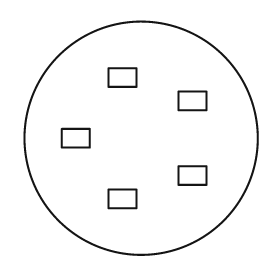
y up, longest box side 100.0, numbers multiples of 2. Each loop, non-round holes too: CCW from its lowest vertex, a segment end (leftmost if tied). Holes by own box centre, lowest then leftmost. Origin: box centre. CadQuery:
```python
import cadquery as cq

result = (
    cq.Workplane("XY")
    .moveTo(0.0, 0.0)
    .circle(50.0)
    .moveTo(-14.0, -30.0)
    .lineTo(-2.0, -30.0)
    .lineTo(-2.0, -22.0)
    .lineTo(-14.0, -22.0)
    .close()
    .moveTo(16.0, -20.0)
    .lineTo(28.0, -20.0)
    .lineTo(28.0, -12.0)
    .lineTo(16.0, -12.0)
    .close()
    .moveTo(-34.0, -4.0)
    .lineTo(-22.0, -4.0)
    .lineTo(-22.0, 4.0)
    .lineTo(-34.0, 4.0)
    .close()
    .moveTo(16.0, 12.0)
    .lineTo(28.0, 12.0)
    .lineTo(28.0, 20.0)
    .lineTo(16.0, 20.0)
    .close()
    .moveTo(-14.0, 22.0)
    .lineTo(-2.0, 22.0)
    .lineTo(-2.0, 30.0)
    .lineTo(-14.0, 30.0)
    .close()
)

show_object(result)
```